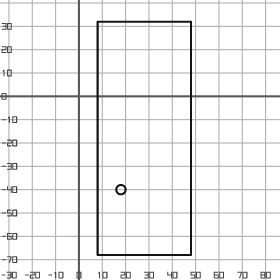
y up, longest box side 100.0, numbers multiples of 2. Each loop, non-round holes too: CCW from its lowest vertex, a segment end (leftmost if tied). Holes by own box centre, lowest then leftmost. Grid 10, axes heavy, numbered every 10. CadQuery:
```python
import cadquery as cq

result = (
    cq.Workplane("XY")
    .moveTo(8.0, -68.0)
    .lineTo(48.0, -68.0)
    .lineTo(48.0, 32.0)
    .lineTo(8.0, 32.0)
    .close()
    .moveTo(18.0, -40.0)
    .circle(2.0)
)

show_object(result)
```